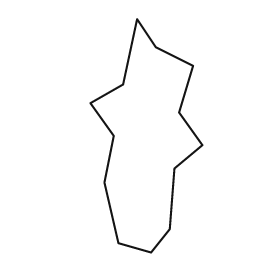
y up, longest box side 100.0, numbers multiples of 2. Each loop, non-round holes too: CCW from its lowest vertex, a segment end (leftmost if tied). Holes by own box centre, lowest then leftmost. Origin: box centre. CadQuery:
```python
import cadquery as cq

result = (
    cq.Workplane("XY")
    .moveTo(2.0, -50.0)
    .lineTo(10.0, -40.0)
    .lineTo(12.0, -14.0)
    .lineTo(24.0, -4.0)
    .lineTo(14.0, 10.0)
    .lineTo(20.0, 30.0)
    .lineTo(4.0, 38.0)
    .lineTo(-4.0, 50.0)
    .lineTo(-10.0, 22.0)
    .lineTo(-24.0, 14.0)
    .lineTo(-14.0, 0.0)
    .lineTo(-18.0, -20.0)
    .lineTo(-12.0, -46.0)
    .close()
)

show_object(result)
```